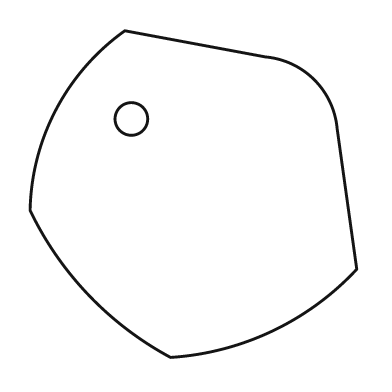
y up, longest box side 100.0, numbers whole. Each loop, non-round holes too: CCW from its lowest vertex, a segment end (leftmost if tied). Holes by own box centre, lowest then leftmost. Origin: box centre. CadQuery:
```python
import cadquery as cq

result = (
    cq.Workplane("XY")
    .moveTo(-7.0, -50.0)
    .threePointArc((24.0, -42.0), (50.0, -23.0))
    .lineTo(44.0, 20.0)
    .threePointArc((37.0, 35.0), (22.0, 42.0))
    .lineTo(-21.0, 50.0)
    .threePointArc((-42.0, 26.0), (-50.0, -5.0))
    .threePointArc((-32.0, -31.0), (-7.0, -50.0))
    .close()
    .moveTo(-19.0, 23.0)
    .circle(5.0)
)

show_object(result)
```